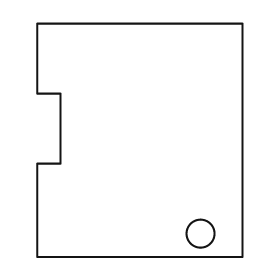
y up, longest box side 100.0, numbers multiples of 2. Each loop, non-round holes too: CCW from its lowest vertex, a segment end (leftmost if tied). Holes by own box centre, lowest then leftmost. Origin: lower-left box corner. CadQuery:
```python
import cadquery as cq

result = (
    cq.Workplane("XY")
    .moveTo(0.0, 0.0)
    .lineTo(88.0, 0.0)
    .lineTo(88.0, 100.0)
    .lineTo(0.0, 100.0)
    .lineTo(0.0, 70.0)
    .lineTo(10.0, 70.0)
    .lineTo(10.0, 40.0)
    .lineTo(0.0, 40.0)
    .close()
    .moveTo(70.0, 10.0)
    .circle(6.0)
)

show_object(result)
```